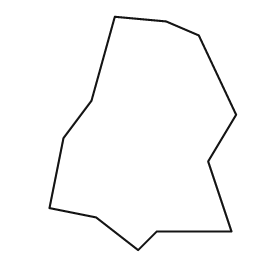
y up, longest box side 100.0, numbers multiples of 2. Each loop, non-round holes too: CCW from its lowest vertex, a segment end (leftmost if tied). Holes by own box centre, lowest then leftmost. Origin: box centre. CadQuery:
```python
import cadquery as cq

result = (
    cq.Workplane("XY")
    .moveTo(-2.0, -50.0)
    .lineTo(6.0, -42.0)
    .lineTo(38.0, -42.0)
    .lineTo(28.0, -12.0)
    .lineTo(40.0, 8.0)
    .lineTo(24.0, 42.0)
    .lineTo(10.0, 48.0)
    .lineTo(-12.0, 50.0)
    .lineTo(-22.0, 14.0)
    .lineTo(-34.0, -2.0)
    .lineTo(-40.0, -32.0)
    .lineTo(-20.0, -36.0)
    .close()
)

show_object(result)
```